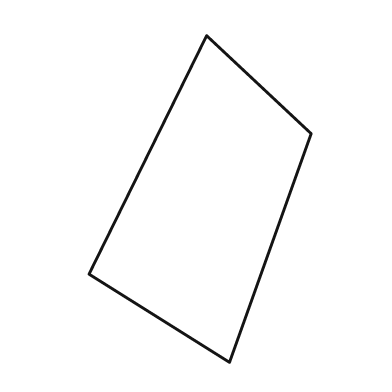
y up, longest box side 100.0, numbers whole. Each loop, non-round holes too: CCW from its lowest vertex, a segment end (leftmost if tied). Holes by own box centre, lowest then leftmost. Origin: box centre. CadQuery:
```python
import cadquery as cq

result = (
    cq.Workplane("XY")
    .moveTo(9.0, -50.0)
    .lineTo(34.0, 20.0)
    .lineTo(2.0, 50.0)
    .lineTo(-34.0, -23.0)
    .close()
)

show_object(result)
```